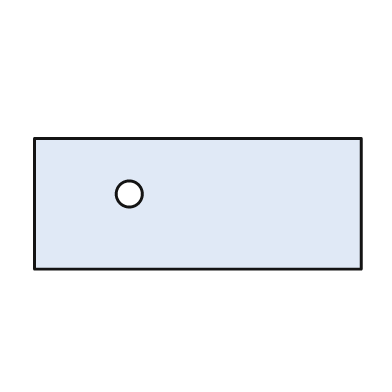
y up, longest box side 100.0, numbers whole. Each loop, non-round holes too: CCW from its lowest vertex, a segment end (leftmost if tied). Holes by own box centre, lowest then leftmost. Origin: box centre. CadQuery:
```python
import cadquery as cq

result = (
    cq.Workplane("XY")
    .moveTo(-50.0, -20.0)
    .lineTo(50.0, -20.0)
    .lineTo(50.0, 20.0)
    .lineTo(-50.0, 20.0)
    .close()
    .moveTo(-21.0, 3.0)
    .circle(4.0)
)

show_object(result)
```